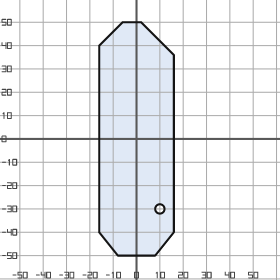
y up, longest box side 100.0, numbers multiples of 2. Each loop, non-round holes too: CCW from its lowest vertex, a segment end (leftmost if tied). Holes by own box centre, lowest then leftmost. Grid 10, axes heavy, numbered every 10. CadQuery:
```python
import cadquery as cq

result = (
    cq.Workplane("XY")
    .moveTo(-8.0, -50.0)
    .lineTo(8.0, -50.0)
    .lineTo(16.0, -40.0)
    .lineTo(16.0, 36.0)
    .lineTo(2.0, 50.0)
    .lineTo(-6.0, 50.0)
    .lineTo(-16.0, 40.0)
    .lineTo(-16.0, -40.0)
    .close()
    .moveTo(10.0, -30.0)
    .circle(2.0)
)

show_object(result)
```